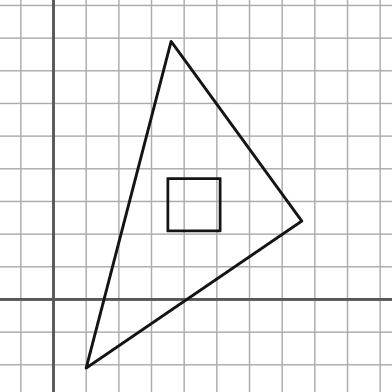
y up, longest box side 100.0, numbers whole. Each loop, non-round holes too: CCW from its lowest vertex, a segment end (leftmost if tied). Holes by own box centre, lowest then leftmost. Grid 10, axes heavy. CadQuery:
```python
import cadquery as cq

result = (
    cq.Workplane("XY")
    .moveTo(10.0, -21.0)
    .lineTo(76.0, 24.0)
    .lineTo(36.0, 79.0)
    .close()
    .moveTo(35.0, 21.0)
    .lineTo(51.0, 21.0)
    .lineTo(51.0, 37.0)
    .lineTo(35.0, 37.0)
    .close()
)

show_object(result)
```